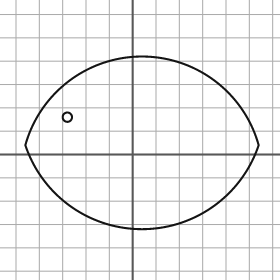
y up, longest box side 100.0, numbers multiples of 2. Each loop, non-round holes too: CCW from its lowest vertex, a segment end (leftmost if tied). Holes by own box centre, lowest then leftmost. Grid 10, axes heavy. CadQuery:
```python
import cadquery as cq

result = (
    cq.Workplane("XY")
    .moveTo(-46.0, 4.0)
    .threePointArc((4.0, -32.0), (54.0, 4.0))
    .threePointArc((4.0, 42.0), (-46.0, 4.0))
    .close()
    .moveTo(-28.0, 16.0)
    .circle(2.0)
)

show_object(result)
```